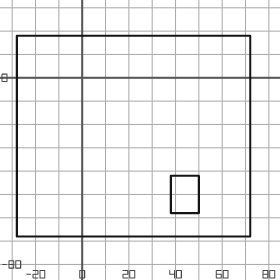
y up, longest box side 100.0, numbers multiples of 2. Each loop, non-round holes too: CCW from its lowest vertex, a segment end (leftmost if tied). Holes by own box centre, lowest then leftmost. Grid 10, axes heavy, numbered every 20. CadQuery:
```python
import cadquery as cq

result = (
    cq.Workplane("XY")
    .moveTo(-28.0, -68.0)
    .lineTo(72.0, -68.0)
    .lineTo(72.0, 18.0)
    .lineTo(-28.0, 18.0)
    .close()
    .moveTo(38.0, -58.0)
    .lineTo(50.0, -58.0)
    .lineTo(50.0, -42.0)
    .lineTo(38.0, -42.0)
    .close()
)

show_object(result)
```